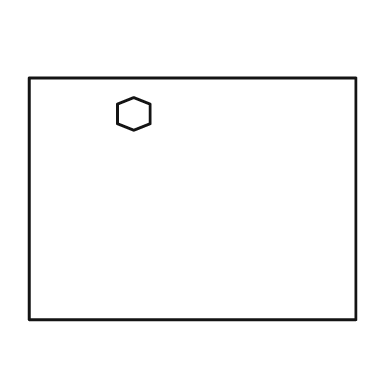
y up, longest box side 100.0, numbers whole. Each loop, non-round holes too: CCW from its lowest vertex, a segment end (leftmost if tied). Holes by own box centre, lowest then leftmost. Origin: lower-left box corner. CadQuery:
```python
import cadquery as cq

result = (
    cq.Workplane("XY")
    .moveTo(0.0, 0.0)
    .lineTo(100.0, 0.0)
    .lineTo(100.0, 74.0)
    .lineTo(0.0, 74.0)
    .close()
    .moveTo(32.0, 58.0)
    .lineTo(37.0, 60.0)
    .lineTo(37.0, 66.0)
    .lineTo(32.0, 68.0)
    .lineTo(27.0, 66.0)
    .lineTo(27.0, 60.0)
    .close()
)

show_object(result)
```